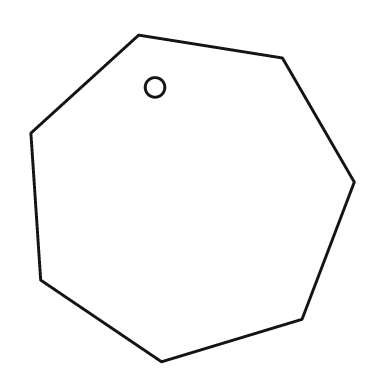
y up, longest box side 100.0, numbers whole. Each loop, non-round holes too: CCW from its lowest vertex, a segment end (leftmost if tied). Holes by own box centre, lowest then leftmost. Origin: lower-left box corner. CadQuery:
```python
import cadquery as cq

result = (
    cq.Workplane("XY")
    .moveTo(40.0, 0.0)
    .lineTo(83.0, 13.0)
    .lineTo(99.0, 55.0)
    .lineTo(77.0, 93.0)
    .lineTo(33.0, 100.0)
    .lineTo(0.0, 70.0)
    .lineTo(3.0, 25.0)
    .close()
    .moveTo(38.0, 84.0)
    .circle(3.0)
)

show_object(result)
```